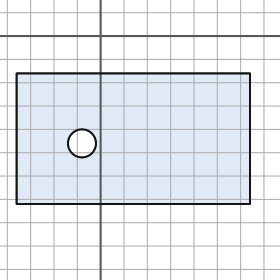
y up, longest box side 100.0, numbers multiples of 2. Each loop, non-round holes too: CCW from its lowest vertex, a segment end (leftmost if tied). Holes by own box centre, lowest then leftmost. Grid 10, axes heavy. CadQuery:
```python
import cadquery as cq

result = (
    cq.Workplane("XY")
    .moveTo(-36.0, -72.0)
    .lineTo(64.0, -72.0)
    .lineTo(64.0, -16.0)
    .lineTo(-36.0, -16.0)
    .close()
    .moveTo(-8.0, -46.0)
    .circle(6.0)
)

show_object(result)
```